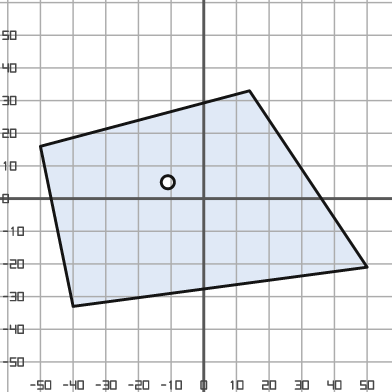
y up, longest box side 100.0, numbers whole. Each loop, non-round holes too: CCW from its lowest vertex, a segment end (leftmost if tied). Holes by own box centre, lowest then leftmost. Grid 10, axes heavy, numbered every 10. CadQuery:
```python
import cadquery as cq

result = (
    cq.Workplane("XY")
    .moveTo(-40.0, -33.0)
    .lineTo(50.0, -21.0)
    .lineTo(14.0, 33.0)
    .lineTo(-50.0, 16.0)
    .close()
    .moveTo(-11.0, 5.0)
    .circle(2.0)
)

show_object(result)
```